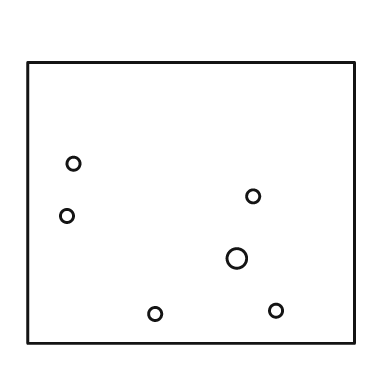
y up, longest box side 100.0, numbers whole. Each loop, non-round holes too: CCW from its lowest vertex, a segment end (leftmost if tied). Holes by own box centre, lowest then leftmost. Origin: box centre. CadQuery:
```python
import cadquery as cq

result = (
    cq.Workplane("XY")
    .moveTo(-50.0, -43.0)
    .lineTo(50.0, -43.0)
    .lineTo(50.0, 43.0)
    .lineTo(-50.0, 43.0)
    .close()
    .moveTo(-11.0, -34.0)
    .circle(2.0)
    .moveTo(26.0, -33.0)
    .circle(2.0)
    .moveTo(14.0, -17.0)
    .circle(3.0)
    .moveTo(-38.0, -4.0)
    .circle(2.0)
    .moveTo(19.0, 2.0)
    .circle(2.0)
    .moveTo(-36.0, 12.0)
    .circle(2.0)
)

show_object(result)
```